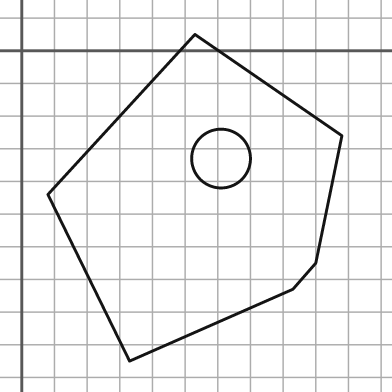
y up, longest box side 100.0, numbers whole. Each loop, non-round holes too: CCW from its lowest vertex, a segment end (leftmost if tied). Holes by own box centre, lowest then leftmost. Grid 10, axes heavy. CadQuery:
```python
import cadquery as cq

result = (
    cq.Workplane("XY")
    .moveTo(33.0, -95.0)
    .lineTo(83.0, -73.0)
    .lineTo(90.0, -65.0)
    .lineTo(98.0, -26.0)
    .lineTo(53.0, 5.0)
    .lineTo(8.0, -44.0)
    .close()
    .moveTo(61.0, -33.0)
    .circle(9.0)
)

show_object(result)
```